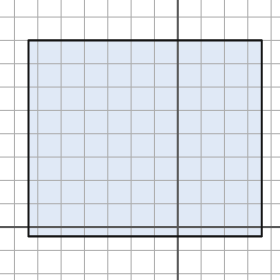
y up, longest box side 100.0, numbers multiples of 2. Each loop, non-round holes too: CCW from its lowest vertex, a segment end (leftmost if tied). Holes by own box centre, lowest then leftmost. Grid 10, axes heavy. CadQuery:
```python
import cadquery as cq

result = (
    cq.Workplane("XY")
    .moveTo(-64.0, -4.0)
    .lineTo(36.0, -4.0)
    .lineTo(36.0, 80.0)
    .lineTo(-64.0, 80.0)
    .close()
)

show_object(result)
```